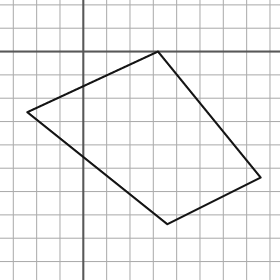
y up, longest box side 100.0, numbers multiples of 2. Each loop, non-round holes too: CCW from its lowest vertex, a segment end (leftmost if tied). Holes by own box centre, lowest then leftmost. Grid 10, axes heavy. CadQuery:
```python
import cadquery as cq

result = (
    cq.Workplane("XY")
    .moveTo(36.0, -74.0)
    .lineTo(76.0, -54.0)
    .lineTo(32.0, 0.0)
    .lineTo(-24.0, -26.0)
    .close()
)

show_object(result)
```